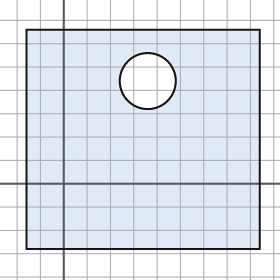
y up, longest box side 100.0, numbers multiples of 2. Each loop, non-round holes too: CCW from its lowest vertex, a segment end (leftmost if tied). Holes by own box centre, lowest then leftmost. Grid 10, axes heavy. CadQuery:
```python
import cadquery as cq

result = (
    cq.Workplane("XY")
    .moveTo(-16.0, -28.0)
    .lineTo(84.0, -28.0)
    .lineTo(84.0, 66.0)
    .lineTo(-16.0, 66.0)
    .close()
    .moveTo(36.0, 44.0)
    .circle(12.0)
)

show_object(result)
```